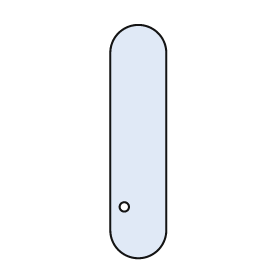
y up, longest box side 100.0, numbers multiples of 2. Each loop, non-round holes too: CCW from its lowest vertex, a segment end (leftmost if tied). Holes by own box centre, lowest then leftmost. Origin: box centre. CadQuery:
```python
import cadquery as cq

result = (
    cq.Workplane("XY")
    .moveTo(-12.0, -38.0)
    .threePointArc((0.0, -50.0), (12.0, -38.0))
    .lineTo(12.0, 38.0)
    .threePointArc((0.0, 50.0), (-12.0, 38.0))
    .close()
    .moveTo(-6.0, -28.0)
    .circle(2.0)
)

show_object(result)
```